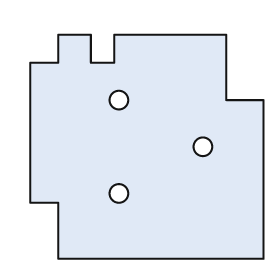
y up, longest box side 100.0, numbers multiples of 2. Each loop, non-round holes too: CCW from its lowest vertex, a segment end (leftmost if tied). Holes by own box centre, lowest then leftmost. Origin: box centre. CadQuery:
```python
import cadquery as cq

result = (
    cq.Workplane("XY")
    .moveTo(-38.0, -48.0)
    .lineTo(50.0, -48.0)
    .lineTo(50.0, 20.0)
    .lineTo(34.0, 20.0)
    .lineTo(34.0, 48.0)
    .lineTo(-14.0, 48.0)
    .lineTo(-14.0, 36.0)
    .lineTo(-24.0, 36.0)
    .lineTo(-24.0, 48.0)
    .lineTo(-38.0, 48.0)
    .lineTo(-38.0, 36.0)
    .lineTo(-50.0, 36.0)
    .lineTo(-50.0, -24.0)
    .lineTo(-38.0, -24.0)
    .close()
    .moveTo(-12.0, -20.0)
    .circle(4.0)
    .moveTo(24.0, 0.0)
    .circle(4.0)
    .moveTo(-12.0, 20.0)
    .circle(4.0)
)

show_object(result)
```